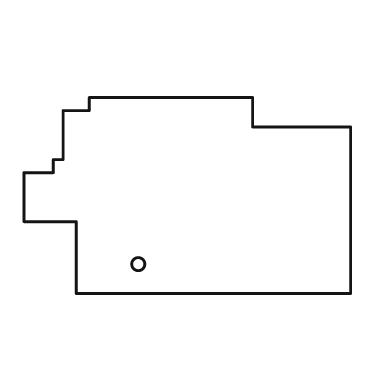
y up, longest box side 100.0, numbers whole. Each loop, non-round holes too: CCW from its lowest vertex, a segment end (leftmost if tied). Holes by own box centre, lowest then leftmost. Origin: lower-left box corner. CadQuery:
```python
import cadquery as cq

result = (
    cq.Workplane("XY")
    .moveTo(16.0, 0.0)
    .lineTo(100.0, 0.0)
    .lineTo(100.0, 51.0)
    .lineTo(70.0, 51.0)
    .lineTo(70.0, 60.0)
    .lineTo(20.0, 60.0)
    .lineTo(20.0, 56.0)
    .lineTo(12.0, 56.0)
    .lineTo(12.0, 41.0)
    .lineTo(9.0, 41.0)
    .lineTo(9.0, 37.0)
    .lineTo(0.0, 37.0)
    .lineTo(0.0, 22.0)
    .lineTo(16.0, 22.0)
    .close()
    .moveTo(35.0, 9.0)
    .circle(2.0)
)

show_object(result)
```